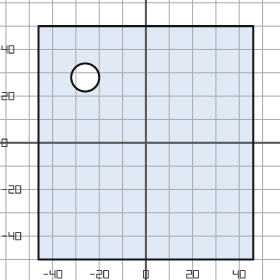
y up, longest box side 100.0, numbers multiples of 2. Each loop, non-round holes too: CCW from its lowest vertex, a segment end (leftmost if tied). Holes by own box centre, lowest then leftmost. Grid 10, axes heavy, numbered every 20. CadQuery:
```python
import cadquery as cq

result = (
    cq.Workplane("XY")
    .moveTo(-46.0, -50.0)
    .lineTo(46.0, -50.0)
    .lineTo(46.0, 50.0)
    .lineTo(-46.0, 50.0)
    .close()
    .moveTo(-26.0, 28.0)
    .circle(6.0)
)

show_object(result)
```